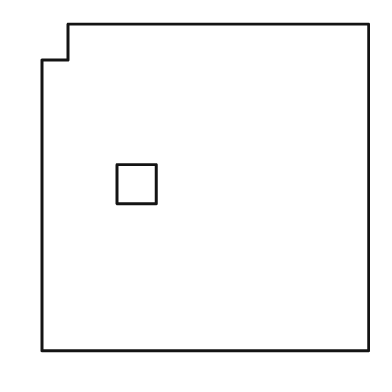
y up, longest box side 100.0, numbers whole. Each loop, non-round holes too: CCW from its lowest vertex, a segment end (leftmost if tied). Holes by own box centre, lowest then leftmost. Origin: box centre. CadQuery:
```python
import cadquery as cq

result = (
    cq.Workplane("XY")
    .moveTo(-50.0, -50.0)
    .lineTo(50.0, -50.0)
    .lineTo(50.0, 50.0)
    .lineTo(-42.0, 50.0)
    .lineTo(-42.0, 39.0)
    .lineTo(-50.0, 39.0)
    .close()
    .moveTo(-27.0, -5.0)
    .lineTo(-15.0, -5.0)
    .lineTo(-15.0, 7.0)
    .lineTo(-27.0, 7.0)
    .close()
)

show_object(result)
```